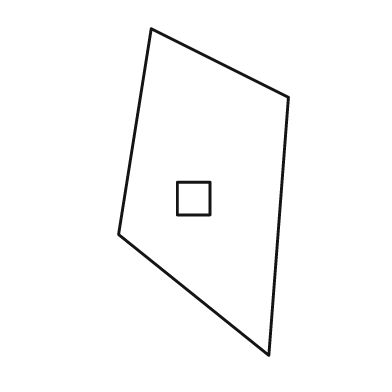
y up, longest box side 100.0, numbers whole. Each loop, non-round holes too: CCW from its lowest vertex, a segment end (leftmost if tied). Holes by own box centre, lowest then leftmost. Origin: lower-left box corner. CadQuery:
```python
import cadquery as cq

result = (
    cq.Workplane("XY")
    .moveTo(46.0, 0.0)
    .lineTo(52.0, 79.0)
    .lineTo(10.0, 100.0)
    .lineTo(0.0, 37.0)
    .close()
    .moveTo(18.0, 43.0)
    .lineTo(28.0, 43.0)
    .lineTo(28.0, 53.0)
    .lineTo(18.0, 53.0)
    .close()
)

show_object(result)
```